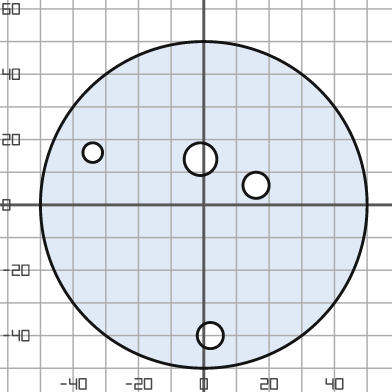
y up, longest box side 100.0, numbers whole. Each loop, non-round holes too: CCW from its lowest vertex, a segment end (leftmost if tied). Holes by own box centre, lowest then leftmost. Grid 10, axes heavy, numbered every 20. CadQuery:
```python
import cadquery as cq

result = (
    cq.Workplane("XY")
    .moveTo(0.0, 0.0)
    .circle(50.0)
    .moveTo(2.0, -40.0)
    .circle(4.0)
    .moveTo(16.0, 6.0)
    .circle(4.0)
    .moveTo(-1.0, 14.0)
    .circle(5.0)
    .moveTo(-34.0, 16.0)
    .circle(3.0)
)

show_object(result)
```